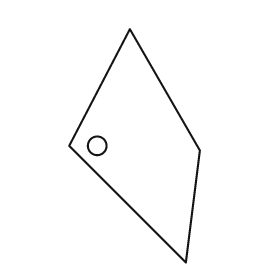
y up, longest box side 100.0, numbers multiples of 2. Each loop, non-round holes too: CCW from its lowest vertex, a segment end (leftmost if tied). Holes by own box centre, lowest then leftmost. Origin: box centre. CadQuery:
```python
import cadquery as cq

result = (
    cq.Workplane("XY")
    .moveTo(22.0, -50.0)
    .lineTo(28.0, -2.0)
    .lineTo(-2.0, 50.0)
    .lineTo(-28.0, 0.0)
    .close()
    .moveTo(-16.0, 0.0)
    .circle(4.0)
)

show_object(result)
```